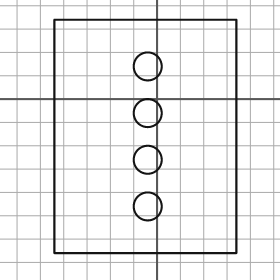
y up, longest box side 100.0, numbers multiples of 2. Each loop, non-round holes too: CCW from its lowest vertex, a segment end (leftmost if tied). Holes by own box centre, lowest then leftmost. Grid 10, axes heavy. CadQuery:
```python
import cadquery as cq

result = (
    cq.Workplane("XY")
    .moveTo(-44.0, -66.0)
    .lineTo(34.0, -66.0)
    .lineTo(34.0, 34.0)
    .lineTo(-44.0, 34.0)
    .close()
    .moveTo(-4.0, -46.0)
    .circle(6.0)
    .moveTo(-4.0, -26.0)
    .circle(6.0)
    .moveTo(-4.0, -6.0)
    .circle(6.0)
    .moveTo(-4.0, 14.0)
    .circle(6.0)
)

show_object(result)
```